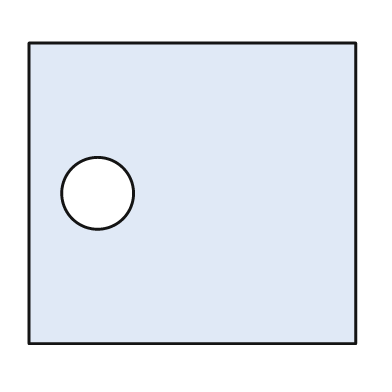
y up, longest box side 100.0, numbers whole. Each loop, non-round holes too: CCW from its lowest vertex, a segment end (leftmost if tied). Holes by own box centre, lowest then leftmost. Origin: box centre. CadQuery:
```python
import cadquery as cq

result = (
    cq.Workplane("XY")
    .moveTo(-50.0, -46.0)
    .lineTo(50.0, -46.0)
    .lineTo(50.0, 46.0)
    .lineTo(-50.0, 46.0)
    .close()
    .moveTo(-29.0, 0.0)
    .circle(11.0)
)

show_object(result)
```